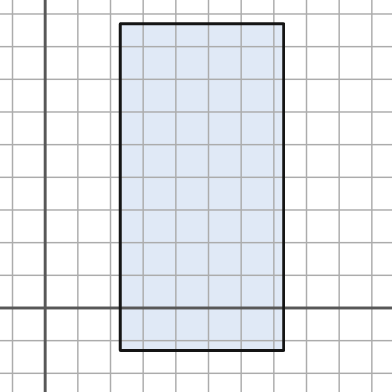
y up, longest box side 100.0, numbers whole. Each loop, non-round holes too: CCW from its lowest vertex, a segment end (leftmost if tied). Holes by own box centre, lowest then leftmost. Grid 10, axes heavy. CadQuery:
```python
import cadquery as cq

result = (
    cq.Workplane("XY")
    .moveTo(23.0, -13.0)
    .lineTo(73.0, -13.0)
    .lineTo(73.0, 87.0)
    .lineTo(23.0, 87.0)
    .close()
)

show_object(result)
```